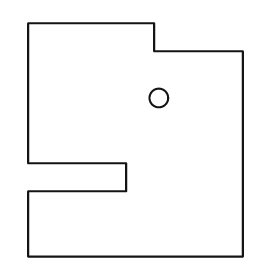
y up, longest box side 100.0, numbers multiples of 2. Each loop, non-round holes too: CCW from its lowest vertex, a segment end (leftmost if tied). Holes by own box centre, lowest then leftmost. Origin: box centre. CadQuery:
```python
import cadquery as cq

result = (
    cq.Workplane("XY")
    .moveTo(-46.0, -50.0)
    .lineTo(46.0, -50.0)
    .lineTo(46.0, 38.0)
    .lineTo(8.0, 38.0)
    .lineTo(8.0, 50.0)
    .lineTo(-46.0, 50.0)
    .lineTo(-46.0, -10.0)
    .lineTo(-4.0, -10.0)
    .lineTo(-4.0, -22.0)
    .lineTo(-46.0, -22.0)
    .close()
    .moveTo(10.0, 18.0)
    .circle(4.0)
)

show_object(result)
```